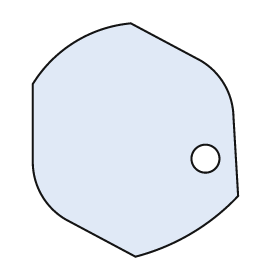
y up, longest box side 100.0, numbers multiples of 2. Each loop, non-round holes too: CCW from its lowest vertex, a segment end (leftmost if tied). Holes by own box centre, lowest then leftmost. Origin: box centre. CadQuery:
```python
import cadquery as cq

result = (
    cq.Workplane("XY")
    .moveTo(0.0, -50.0)
    .threePointArc((24.0, -40.0), (44.0, -24.0))
    .lineTo(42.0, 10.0)
    .threePointArc((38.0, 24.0), (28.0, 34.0))
    .lineTo(-2.0, 50.0)
    .threePointArc((-26.0, 42.0), (-44.0, 24.0))
    .lineTo(-44.0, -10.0)
    .threePointArc((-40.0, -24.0), (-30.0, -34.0))
    .close()
    .moveTo(30.0, -8.0)
    .circle(6.0)
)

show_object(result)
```